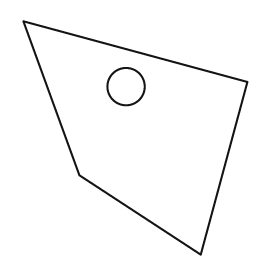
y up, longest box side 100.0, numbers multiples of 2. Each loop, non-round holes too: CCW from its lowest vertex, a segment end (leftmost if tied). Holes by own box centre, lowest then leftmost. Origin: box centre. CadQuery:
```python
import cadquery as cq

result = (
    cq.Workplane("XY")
    .moveTo(28.0, -50.0)
    .lineTo(48.0, 24.0)
    .lineTo(-48.0, 50.0)
    .lineTo(-24.0, -16.0)
    .close()
    .moveTo(-4.0, 22.0)
    .circle(8.0)
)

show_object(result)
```